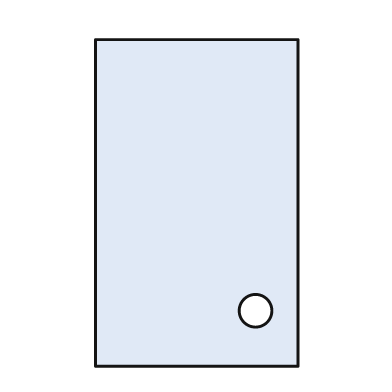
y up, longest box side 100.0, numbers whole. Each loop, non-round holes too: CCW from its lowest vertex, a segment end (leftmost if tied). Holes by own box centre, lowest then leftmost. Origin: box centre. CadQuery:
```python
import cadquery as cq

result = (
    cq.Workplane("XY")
    .moveTo(-31.0, -50.0)
    .lineTo(31.0, -50.0)
    .lineTo(31.0, 50.0)
    .lineTo(-31.0, 50.0)
    .close()
    .moveTo(18.0, -33.0)
    .circle(5.0)
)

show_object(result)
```